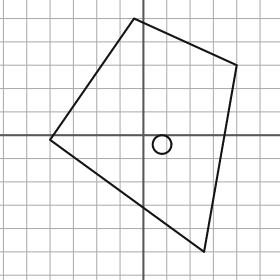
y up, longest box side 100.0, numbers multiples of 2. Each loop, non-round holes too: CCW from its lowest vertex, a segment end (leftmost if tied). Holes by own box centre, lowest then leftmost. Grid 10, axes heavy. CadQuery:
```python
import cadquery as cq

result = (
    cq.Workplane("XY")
    .moveTo(26.0, -50.0)
    .lineTo(40.0, 30.0)
    .lineTo(-4.0, 50.0)
    .lineTo(-40.0, -2.0)
    .close()
    .moveTo(8.0, -4.0)
    .circle(4.0)
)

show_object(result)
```